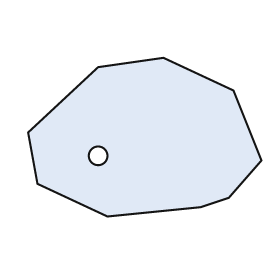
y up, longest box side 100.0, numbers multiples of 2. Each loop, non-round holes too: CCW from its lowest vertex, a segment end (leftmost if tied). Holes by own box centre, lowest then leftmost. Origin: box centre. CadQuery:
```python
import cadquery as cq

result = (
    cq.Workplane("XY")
    .moveTo(-16.0, -34.0)
    .lineTo(24.0, -30.0)
    .lineTo(36.0, -26.0)
    .lineTo(50.0, -10.0)
    .lineTo(38.0, 20.0)
    .lineTo(8.0, 34.0)
    .lineTo(-20.0, 30.0)
    .lineTo(-50.0, 2.0)
    .lineTo(-46.0, -20.0)
    .close()
    .moveTo(-20.0, -8.0)
    .circle(4.0)
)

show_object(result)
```